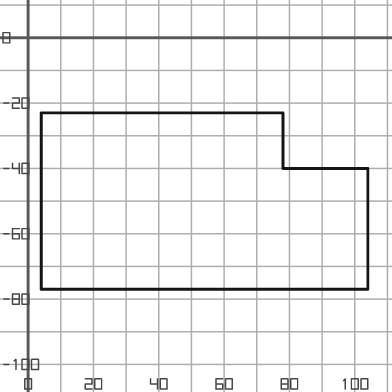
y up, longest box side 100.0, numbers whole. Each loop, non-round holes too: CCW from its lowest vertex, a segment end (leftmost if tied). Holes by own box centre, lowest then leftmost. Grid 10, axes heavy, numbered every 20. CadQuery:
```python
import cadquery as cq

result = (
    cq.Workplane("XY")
    .moveTo(4.0, -77.0)
    .lineTo(104.0, -77.0)
    .lineTo(104.0, -40.0)
    .lineTo(78.0, -40.0)
    .lineTo(78.0, -23.0)
    .lineTo(4.0, -23.0)
    .close()
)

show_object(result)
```